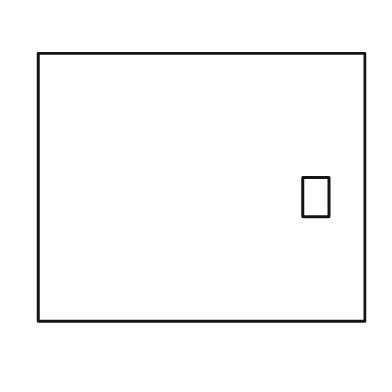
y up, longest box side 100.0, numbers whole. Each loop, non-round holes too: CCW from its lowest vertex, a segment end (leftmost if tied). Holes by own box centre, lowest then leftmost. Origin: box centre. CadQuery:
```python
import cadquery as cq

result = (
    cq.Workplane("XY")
    .moveTo(-50.0, -41.0)
    .lineTo(50.0, -41.0)
    .lineTo(50.0, 41.0)
    .lineTo(-50.0, 41.0)
    .close()
    .moveTo(31.0, -9.0)
    .lineTo(39.0, -9.0)
    .lineTo(39.0, 3.0)
    .lineTo(31.0, 3.0)
    .close()
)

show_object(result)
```